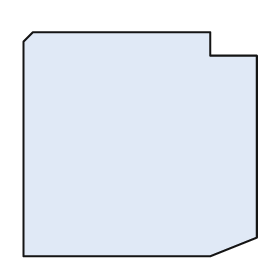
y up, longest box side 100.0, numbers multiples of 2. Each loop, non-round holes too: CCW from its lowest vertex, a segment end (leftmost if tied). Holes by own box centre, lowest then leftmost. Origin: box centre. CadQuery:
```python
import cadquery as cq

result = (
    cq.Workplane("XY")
    .moveTo(-50.0, -48.0)
    .lineTo(30.0, -48.0)
    .lineTo(50.0, -40.0)
    .lineTo(50.0, 38.0)
    .lineTo(30.0, 38.0)
    .lineTo(30.0, 48.0)
    .lineTo(-46.0, 48.0)
    .lineTo(-50.0, 44.0)
    .close()
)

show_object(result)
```